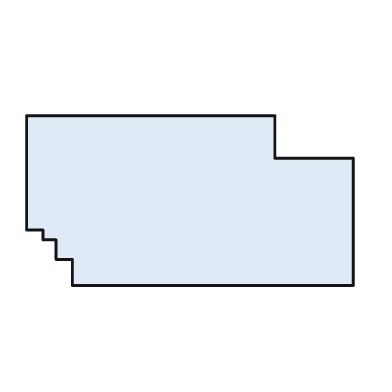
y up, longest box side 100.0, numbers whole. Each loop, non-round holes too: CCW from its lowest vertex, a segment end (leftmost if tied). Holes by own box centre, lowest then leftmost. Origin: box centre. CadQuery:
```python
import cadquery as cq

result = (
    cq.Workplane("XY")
    .moveTo(-36.0, -26.0)
    .lineTo(50.0, -26.0)
    .lineTo(50.0, 13.0)
    .lineTo(26.0, 13.0)
    .lineTo(26.0, 26.0)
    .lineTo(-50.0, 26.0)
    .lineTo(-50.0, -9.0)
    .lineTo(-45.0, -9.0)
    .lineTo(-45.0, -12.0)
    .lineTo(-41.0, -12.0)
    .lineTo(-41.0, -18.0)
    .lineTo(-36.0, -18.0)
    .close()
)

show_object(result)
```